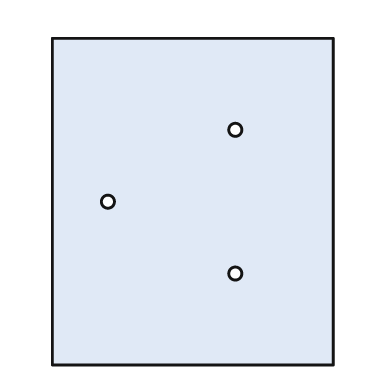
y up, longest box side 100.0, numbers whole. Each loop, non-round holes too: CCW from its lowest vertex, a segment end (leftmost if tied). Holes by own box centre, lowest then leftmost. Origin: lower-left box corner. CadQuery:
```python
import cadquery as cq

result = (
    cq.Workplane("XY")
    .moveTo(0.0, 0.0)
    .lineTo(86.0, 0.0)
    .lineTo(86.0, 100.0)
    .lineTo(0.0, 100.0)
    .close()
    .moveTo(56.0, 28.0)
    .circle(2.0)
    .moveTo(17.0, 50.0)
    .circle(2.0)
    .moveTo(56.0, 72.0)
    .circle(2.0)
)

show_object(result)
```